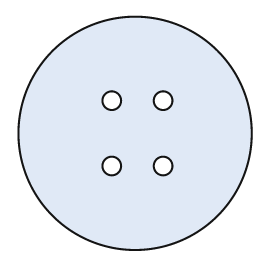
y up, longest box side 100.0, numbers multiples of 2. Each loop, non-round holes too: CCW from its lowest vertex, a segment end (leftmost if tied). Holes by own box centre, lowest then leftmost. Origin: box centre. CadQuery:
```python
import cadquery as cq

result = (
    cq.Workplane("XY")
    .moveTo(0.0, 0.0)
    .circle(50.0)
    .moveTo(-10.0, -14.0)
    .circle(4.0)
    .moveTo(12.0, -14.0)
    .circle(4.0)
    .moveTo(-10.0, 14.0)
    .circle(4.0)
    .moveTo(12.0, 14.0)
    .circle(4.0)
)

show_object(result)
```